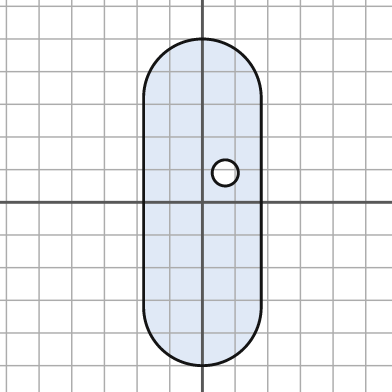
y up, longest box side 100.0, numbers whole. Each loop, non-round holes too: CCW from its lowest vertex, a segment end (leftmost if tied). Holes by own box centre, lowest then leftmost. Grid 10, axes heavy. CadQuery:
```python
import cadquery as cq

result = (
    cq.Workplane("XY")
    .moveTo(-18.0, -32.0)
    .threePointArc((0.0, -50.0), (18.0, -32.0))
    .lineTo(18.0, 32.0)
    .threePointArc((0.0, 50.0), (-18.0, 32.0))
    .close()
    .moveTo(7.0, 9.0)
    .circle(4.0)
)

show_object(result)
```